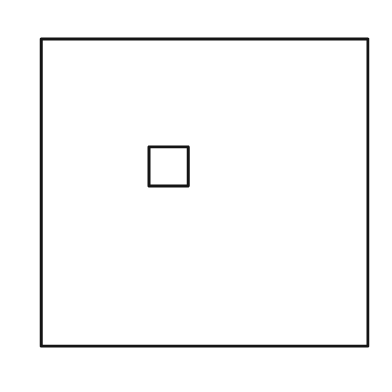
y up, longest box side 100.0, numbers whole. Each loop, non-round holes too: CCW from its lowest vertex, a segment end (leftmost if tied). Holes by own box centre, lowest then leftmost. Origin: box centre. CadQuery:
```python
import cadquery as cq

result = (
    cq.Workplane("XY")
    .moveTo(-50.0, -47.0)
    .lineTo(50.0, -47.0)
    .lineTo(50.0, 47.0)
    .lineTo(-50.0, 47.0)
    .close()
    .moveTo(-17.0, 2.0)
    .lineTo(-5.0, 2.0)
    .lineTo(-5.0, 14.0)
    .lineTo(-17.0, 14.0)
    .close()
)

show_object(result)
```